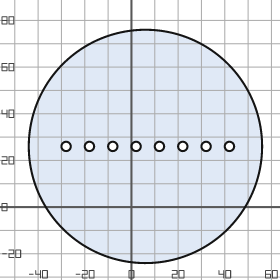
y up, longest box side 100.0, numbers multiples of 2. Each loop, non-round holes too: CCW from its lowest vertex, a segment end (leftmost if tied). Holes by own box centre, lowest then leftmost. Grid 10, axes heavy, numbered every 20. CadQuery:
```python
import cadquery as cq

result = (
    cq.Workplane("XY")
    .moveTo(6.0, 26.0)
    .circle(50.0)
    .moveTo(-28.0, 26.0)
    .circle(2.0)
    .moveTo(-18.0, 26.0)
    .circle(2.0)
    .moveTo(-8.0, 26.0)
    .circle(2.0)
    .moveTo(2.0, 26.0)
    .circle(2.0)
    .moveTo(12.0, 26.0)
    .circle(2.0)
    .moveTo(22.0, 26.0)
    .circle(2.0)
    .moveTo(32.0, 26.0)
    .circle(2.0)
    .moveTo(42.0, 26.0)
    .circle(2.0)
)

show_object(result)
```